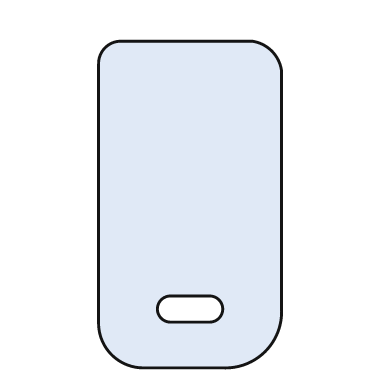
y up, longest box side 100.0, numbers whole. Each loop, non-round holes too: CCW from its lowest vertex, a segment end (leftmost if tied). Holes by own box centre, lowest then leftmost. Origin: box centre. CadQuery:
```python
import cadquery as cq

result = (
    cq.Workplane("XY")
    .moveTo(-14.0, -50.0)
    .lineTo(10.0, -50.0)
    .threePointArc((23.0, -45.0), (28.0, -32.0))
    .lineTo(28.0, 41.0)
    .threePointArc((25.0, 47.0), (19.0, 50.0))
    .lineTo(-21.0, 50.0)
    .threePointArc((-26.0, 48.0), (-28.0, 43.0))
    .lineTo(-28.0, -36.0)
    .threePointArc((-24.0, -46.0), (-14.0, -50.0))
    .close()
    .moveTo(-6.0, -36.0)
    .lineTo(6.0, -36.0)
    .threePointArc((10.0, -32.0), (6.0, -28.0))
    .lineTo(-6.0, -28.0)
    .threePointArc((-10.0, -32.0), (-6.0, -36.0))
    .close()
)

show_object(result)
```